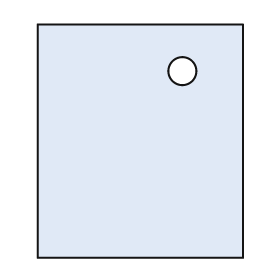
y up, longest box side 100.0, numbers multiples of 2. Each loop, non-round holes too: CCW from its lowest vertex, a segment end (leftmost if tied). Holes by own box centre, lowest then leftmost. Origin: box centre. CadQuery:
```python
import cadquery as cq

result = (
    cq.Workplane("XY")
    .moveTo(-44.0, -50.0)
    .lineTo(44.0, -50.0)
    .lineTo(44.0, 50.0)
    .lineTo(-44.0, 50.0)
    .close()
    .moveTo(18.0, 30.0)
    .circle(6.0)
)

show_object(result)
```